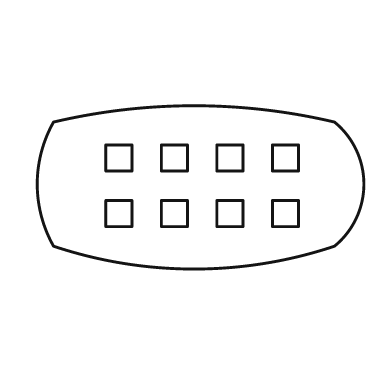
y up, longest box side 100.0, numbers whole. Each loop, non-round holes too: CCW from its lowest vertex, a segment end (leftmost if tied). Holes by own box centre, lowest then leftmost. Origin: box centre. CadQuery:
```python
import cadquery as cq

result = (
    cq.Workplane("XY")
    .moveTo(-45.0, -18.0)
    .threePointArc((-2.0, -25.0), (41.0, -18.0))
    .threePointArc((50.0, 1.0), (41.0, 20.0))
    .threePointArc((-2.0, 25.0), (-45.0, 20.0))
    .threePointArc((-50.0, 1.0), (-45.0, -18.0))
    .close()
    .moveTo(-29.0, -12.0)
    .lineTo(-21.0, -12.0)
    .lineTo(-21.0, -4.0)
    .lineTo(-29.0, -4.0)
    .close()
    .moveTo(-12.0, -12.0)
    .lineTo(-4.0, -12.0)
    .lineTo(-4.0, -4.0)
    .lineTo(-12.0, -4.0)
    .close()
    .moveTo(5.0, -12.0)
    .lineTo(13.0, -12.0)
    .lineTo(13.0, -4.0)
    .lineTo(5.0, -4.0)
    .close()
    .moveTo(22.0, -12.0)
    .lineTo(30.0, -12.0)
    .lineTo(30.0, -4.0)
    .lineTo(22.0, -4.0)
    .close()
    .moveTo(-29.0, 5.0)
    .lineTo(-21.0, 5.0)
    .lineTo(-21.0, 13.0)
    .lineTo(-29.0, 13.0)
    .close()
    .moveTo(-12.0, 5.0)
    .lineTo(-4.0, 5.0)
    .lineTo(-4.0, 13.0)
    .lineTo(-12.0, 13.0)
    .close()
    .moveTo(5.0, 5.0)
    .lineTo(13.0, 5.0)
    .lineTo(13.0, 13.0)
    .lineTo(5.0, 13.0)
    .close()
    .moveTo(22.0, 5.0)
    .lineTo(30.0, 5.0)
    .lineTo(30.0, 13.0)
    .lineTo(22.0, 13.0)
    .close()
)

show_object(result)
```